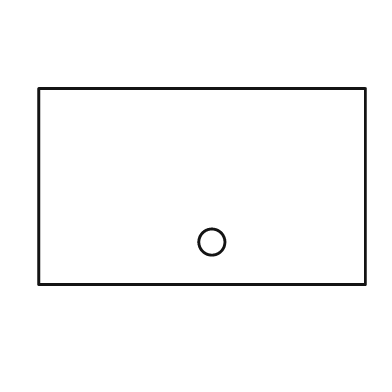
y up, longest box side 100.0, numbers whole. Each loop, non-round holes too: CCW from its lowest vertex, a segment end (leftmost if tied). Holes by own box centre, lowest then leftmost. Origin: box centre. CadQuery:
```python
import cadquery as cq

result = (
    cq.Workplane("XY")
    .moveTo(-50.0, -30.0)
    .lineTo(50.0, -30.0)
    .lineTo(50.0, 30.0)
    .lineTo(-50.0, 30.0)
    .close()
    .moveTo(3.0, -17.0)
    .circle(4.0)
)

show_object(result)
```